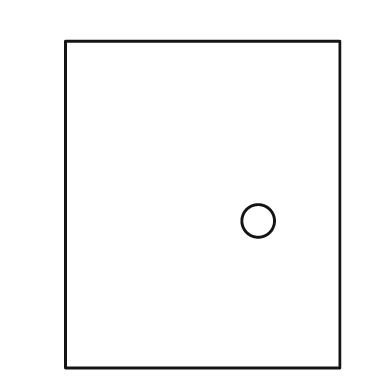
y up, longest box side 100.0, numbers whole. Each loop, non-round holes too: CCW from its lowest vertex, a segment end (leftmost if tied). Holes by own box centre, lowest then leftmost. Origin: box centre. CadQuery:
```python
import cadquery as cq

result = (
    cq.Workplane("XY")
    .moveTo(-42.0, -50.0)
    .lineTo(42.0, -50.0)
    .lineTo(42.0, 50.0)
    .lineTo(-42.0, 50.0)
    .close()
    .moveTo(17.0, -5.0)
    .circle(5.0)
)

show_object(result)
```